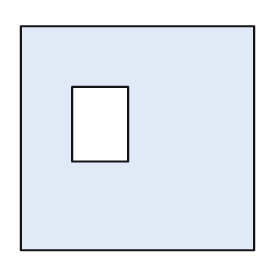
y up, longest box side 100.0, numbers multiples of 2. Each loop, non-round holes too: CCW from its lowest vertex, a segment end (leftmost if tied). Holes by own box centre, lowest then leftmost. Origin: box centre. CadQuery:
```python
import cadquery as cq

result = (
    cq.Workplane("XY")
    .moveTo(-50.0, -48.0)
    .lineTo(50.0, -48.0)
    .lineTo(50.0, 48.0)
    .lineTo(-50.0, 48.0)
    .close()
    .moveTo(-28.0, -10.0)
    .lineTo(-4.0, -10.0)
    .lineTo(-4.0, 22.0)
    .lineTo(-28.0, 22.0)
    .close()
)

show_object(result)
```